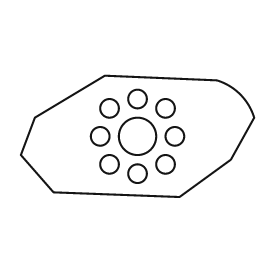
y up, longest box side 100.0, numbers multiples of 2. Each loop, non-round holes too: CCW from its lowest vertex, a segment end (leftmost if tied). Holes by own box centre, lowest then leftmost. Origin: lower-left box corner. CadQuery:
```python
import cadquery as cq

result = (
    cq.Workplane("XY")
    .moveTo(68.0, 0.0)
    .lineTo(90.0, 16.0)
    .lineTo(100.0, 34.0)
    .threePointArc((94.0, 44.0), (84.0, 50.0))
    .lineTo(36.0, 52.0)
    .lineTo(6.0, 34.0)
    .lineTo(0.0, 18.0)
    .lineTo(14.0, 2.0)
    .close()
    .moveTo(50.0, 10.0)
    .circle(4.0)
    .moveTo(38.0, 14.0)
    .circle(4.0)
    .moveTo(62.0, 14.0)
    .circle(4.0)
    .moveTo(34.0, 26.0)
    .circle(4.0)
    .moveTo(50.0, 26.0)
    .circle(8.0)
    .moveTo(66.0, 26.0)
    .circle(4.0)
    .moveTo(38.0, 38.0)
    .circle(4.0)
    .moveTo(62.0, 38.0)
    .circle(4.0)
    .moveTo(50.0, 42.0)
    .circle(4.0)
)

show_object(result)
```